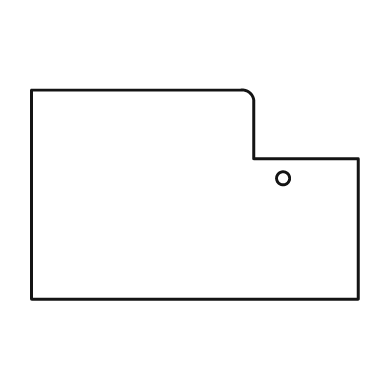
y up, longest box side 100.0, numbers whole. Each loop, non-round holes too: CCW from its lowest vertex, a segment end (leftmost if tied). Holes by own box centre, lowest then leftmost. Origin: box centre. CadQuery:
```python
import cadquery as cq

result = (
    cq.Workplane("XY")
    .moveTo(-50.0, -32.0)
    .lineTo(50.0, -32.0)
    .lineTo(50.0, 11.0)
    .lineTo(18.0, 11.0)
    .lineTo(18.0, 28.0)
    .threePointArc((17.0, 31.0), (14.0, 32.0))
    .lineTo(-50.0, 32.0)
    .close()
    .moveTo(27.0, 5.0)
    .circle(2.0)
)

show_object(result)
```